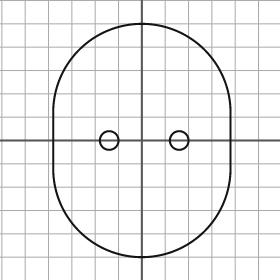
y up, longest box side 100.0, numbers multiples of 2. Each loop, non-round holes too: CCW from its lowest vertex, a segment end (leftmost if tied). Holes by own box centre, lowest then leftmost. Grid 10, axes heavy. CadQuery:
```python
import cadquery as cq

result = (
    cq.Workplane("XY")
    .moveTo(-38.0, -12.0)
    .threePointArc((0.0, -50.0), (38.0, -12.0))
    .lineTo(38.0, 12.0)
    .threePointArc((0.0, 50.0), (-38.0, 12.0))
    .close()
    .moveTo(-14.0, 0.0)
    .circle(4.0)
    .moveTo(16.0, 0.0)
    .circle(4.0)
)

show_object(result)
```